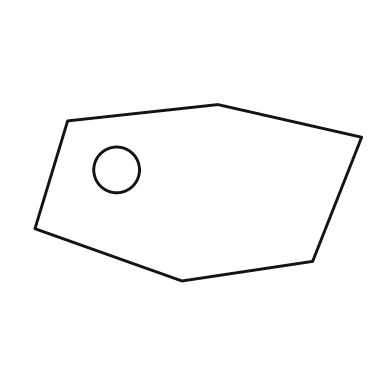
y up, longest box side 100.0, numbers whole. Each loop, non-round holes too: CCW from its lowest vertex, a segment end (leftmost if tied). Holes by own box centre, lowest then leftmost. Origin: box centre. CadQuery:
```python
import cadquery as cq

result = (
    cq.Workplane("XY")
    .moveTo(-5.0, -27.0)
    .lineTo(35.0, -21.0)
    .lineTo(50.0, 17.0)
    .lineTo(6.0, 27.0)
    .lineTo(-40.0, 22.0)
    .lineTo(-50.0, -11.0)
    .close()
    .moveTo(-25.0, 7.0)
    .circle(7.0)
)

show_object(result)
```